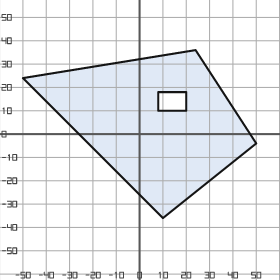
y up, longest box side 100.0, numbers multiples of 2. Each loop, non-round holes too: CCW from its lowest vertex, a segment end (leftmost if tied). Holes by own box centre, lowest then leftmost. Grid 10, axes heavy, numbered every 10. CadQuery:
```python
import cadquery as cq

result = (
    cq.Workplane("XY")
    .moveTo(10.0, -36.0)
    .lineTo(50.0, -4.0)
    .lineTo(24.0, 36.0)
    .lineTo(-50.0, 24.0)
    .close()
    .moveTo(8.0, 10.0)
    .lineTo(20.0, 10.0)
    .lineTo(20.0, 18.0)
    .lineTo(8.0, 18.0)
    .close()
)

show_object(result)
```